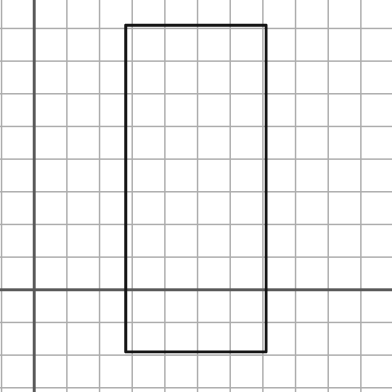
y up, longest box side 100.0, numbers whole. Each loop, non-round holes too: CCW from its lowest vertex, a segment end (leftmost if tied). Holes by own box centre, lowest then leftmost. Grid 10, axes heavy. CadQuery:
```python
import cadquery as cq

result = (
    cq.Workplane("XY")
    .moveTo(28.0, -19.0)
    .lineTo(71.0, -19.0)
    .lineTo(71.0, 81.0)
    .lineTo(28.0, 81.0)
    .close()
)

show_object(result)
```